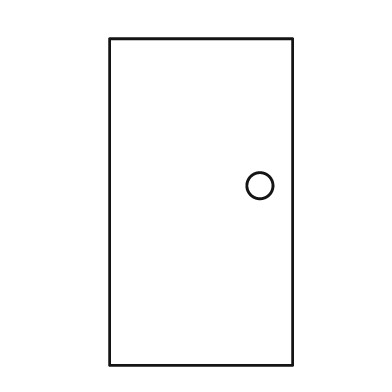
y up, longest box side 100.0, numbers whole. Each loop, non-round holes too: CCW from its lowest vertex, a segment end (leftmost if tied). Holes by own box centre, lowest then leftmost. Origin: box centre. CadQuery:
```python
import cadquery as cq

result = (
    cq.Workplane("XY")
    .moveTo(-28.0, -50.0)
    .lineTo(28.0, -50.0)
    .lineTo(28.0, 50.0)
    .lineTo(-28.0, 50.0)
    .close()
    .moveTo(18.0, 5.0)
    .circle(4.0)
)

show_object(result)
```